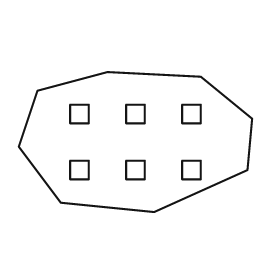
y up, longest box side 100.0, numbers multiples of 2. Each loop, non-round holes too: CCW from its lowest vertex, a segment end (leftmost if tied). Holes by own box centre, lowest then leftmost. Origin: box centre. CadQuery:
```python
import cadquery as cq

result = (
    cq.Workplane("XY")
    .moveTo(8.0, -30.0)
    .lineTo(48.0, -12.0)
    .lineTo(50.0, 10.0)
    .lineTo(28.0, 28.0)
    .lineTo(-12.0, 30.0)
    .lineTo(-42.0, 22.0)
    .lineTo(-50.0, -2.0)
    .lineTo(-32.0, -26.0)
    .close()
    .moveTo(-28.0, -16.0)
    .lineTo(-20.0, -16.0)
    .lineTo(-20.0, -8.0)
    .lineTo(-28.0, -8.0)
    .close()
    .moveTo(-4.0, -16.0)
    .lineTo(4.0, -16.0)
    .lineTo(4.0, -8.0)
    .lineTo(-4.0, -8.0)
    .close()
    .moveTo(20.0, -16.0)
    .lineTo(28.0, -16.0)
    .lineTo(28.0, -8.0)
    .lineTo(20.0, -8.0)
    .close()
    .moveTo(-28.0, 8.0)
    .lineTo(-20.0, 8.0)
    .lineTo(-20.0, 16.0)
    .lineTo(-28.0, 16.0)
    .close()
    .moveTo(-4.0, 8.0)
    .lineTo(4.0, 8.0)
    .lineTo(4.0, 16.0)
    .lineTo(-4.0, 16.0)
    .close()
    .moveTo(20.0, 8.0)
    .lineTo(28.0, 8.0)
    .lineTo(28.0, 16.0)
    .lineTo(20.0, 16.0)
    .close()
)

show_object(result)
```